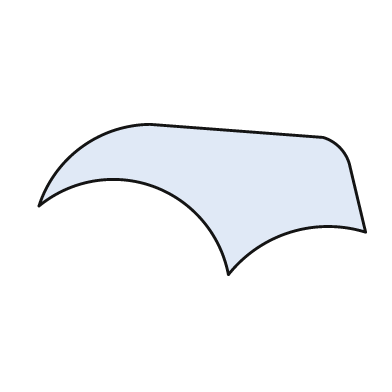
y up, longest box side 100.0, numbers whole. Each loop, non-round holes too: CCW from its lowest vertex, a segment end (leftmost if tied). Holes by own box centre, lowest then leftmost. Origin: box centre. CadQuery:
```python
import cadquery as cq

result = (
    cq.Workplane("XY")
    .moveTo(8.0, -23.0)
    .threePointArc((27.0, -10.0), (50.0, -10.0))
    .lineTo(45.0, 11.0)
    .threePointArc((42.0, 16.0), (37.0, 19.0))
    .lineTo(-16.0, 23.0)
    .threePointArc((-37.0, 16.0), (-50.0, -2.0))
    .threePointArc((-15.0, 4.0), (8.0, -23.0))
    .close()
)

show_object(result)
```